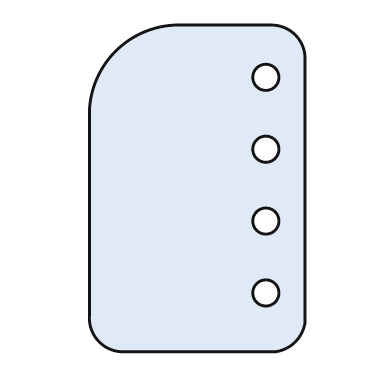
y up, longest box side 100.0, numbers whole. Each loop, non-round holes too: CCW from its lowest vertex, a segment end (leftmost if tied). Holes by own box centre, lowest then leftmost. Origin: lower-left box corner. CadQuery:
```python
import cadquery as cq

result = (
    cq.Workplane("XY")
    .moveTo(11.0, 0.0)
    .lineTo(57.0, 0.0)
    .threePointArc((63.0, 3.0), (66.0, 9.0))
    .lineTo(66.0, 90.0)
    .threePointArc((63.0, 97.0), (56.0, 100.0))
    .lineTo(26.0, 100.0)
    .threePointArc((8.0, 92.0), (0.0, 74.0))
    .lineTo(0.0, 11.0)
    .threePointArc((3.0, 3.0), (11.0, 0.0))
    .close()
    .moveTo(54.0, 18.0)
    .circle(4.0)
    .moveTo(54.0, 40.0)
    .circle(4.0)
    .moveTo(54.0, 62.0)
    .circle(4.0)
    .moveTo(54.0, 84.0)
    .circle(4.0)
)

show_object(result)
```